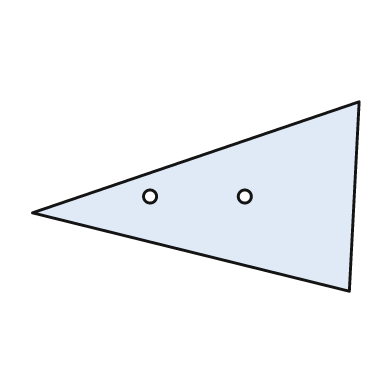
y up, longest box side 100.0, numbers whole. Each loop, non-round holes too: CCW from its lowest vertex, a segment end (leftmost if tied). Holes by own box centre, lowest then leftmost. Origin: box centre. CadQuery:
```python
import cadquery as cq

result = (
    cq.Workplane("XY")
    .moveTo(47.0, -29.0)
    .lineTo(50.0, 29.0)
    .lineTo(-50.0, -5.0)
    .close()
    .moveTo(-14.0, 0.0)
    .circle(2.0)
    .moveTo(15.0, 0.0)
    .circle(2.0)
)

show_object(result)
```